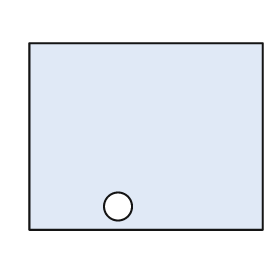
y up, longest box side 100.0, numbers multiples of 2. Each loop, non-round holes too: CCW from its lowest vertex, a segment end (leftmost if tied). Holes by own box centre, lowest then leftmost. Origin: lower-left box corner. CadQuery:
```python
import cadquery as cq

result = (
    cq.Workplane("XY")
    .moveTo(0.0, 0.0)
    .lineTo(100.0, 0.0)
    .lineTo(100.0, 80.0)
    .lineTo(0.0, 80.0)
    .close()
    .moveTo(38.0, 10.0)
    .circle(6.0)
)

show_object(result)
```